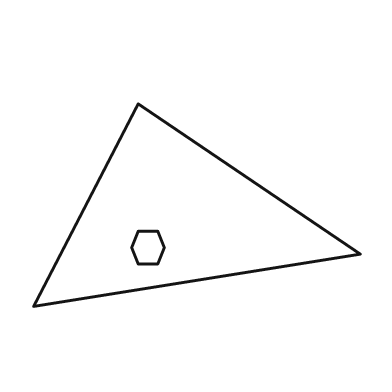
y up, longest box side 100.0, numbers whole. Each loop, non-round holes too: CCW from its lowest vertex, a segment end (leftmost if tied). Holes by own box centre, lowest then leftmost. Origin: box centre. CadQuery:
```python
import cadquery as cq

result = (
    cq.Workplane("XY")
    .moveTo(-50.0, -31.0)
    .lineTo(50.0, -15.0)
    .lineTo(-18.0, 31.0)
    .close()
    .moveTo(-18.0, -18.0)
    .lineTo(-12.0, -18.0)
    .lineTo(-10.0, -13.0)
    .lineTo(-12.0, -8.0)
    .lineTo(-18.0, -8.0)
    .lineTo(-20.0, -13.0)
    .close()
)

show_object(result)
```